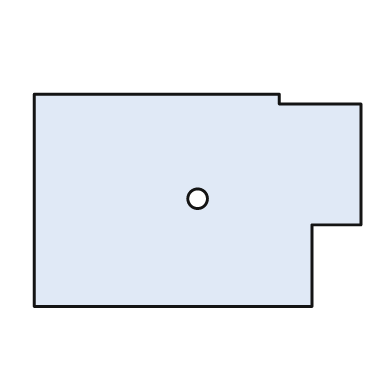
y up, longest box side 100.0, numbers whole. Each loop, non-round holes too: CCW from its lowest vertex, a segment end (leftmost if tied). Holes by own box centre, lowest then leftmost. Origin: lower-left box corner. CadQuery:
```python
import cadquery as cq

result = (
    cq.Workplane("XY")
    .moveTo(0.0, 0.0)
    .lineTo(85.0, 0.0)
    .lineTo(85.0, 25.0)
    .lineTo(100.0, 25.0)
    .lineTo(100.0, 62.0)
    .lineTo(75.0, 62.0)
    .lineTo(75.0, 65.0)
    .lineTo(0.0, 65.0)
    .close()
    .moveTo(50.0, 33.0)
    .circle(3.0)
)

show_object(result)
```